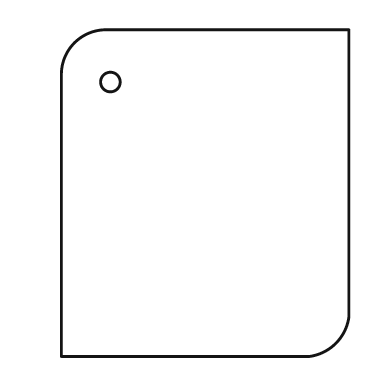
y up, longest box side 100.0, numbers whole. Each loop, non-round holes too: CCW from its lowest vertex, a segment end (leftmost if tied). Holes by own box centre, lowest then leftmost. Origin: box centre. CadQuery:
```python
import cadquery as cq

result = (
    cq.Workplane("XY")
    .moveTo(-44.0, -50.0)
    .lineTo(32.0, -50.0)
    .threePointArc((40.0, -46.0), (44.0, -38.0))
    .lineTo(44.0, 50.0)
    .lineTo(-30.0, 50.0)
    .threePointArc((-40.0, 46.0), (-44.0, 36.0))
    .close()
    .moveTo(-29.0, 34.0)
    .circle(3.0)
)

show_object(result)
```